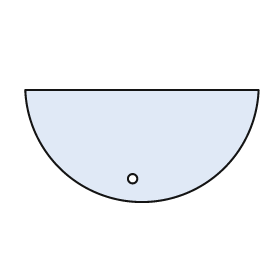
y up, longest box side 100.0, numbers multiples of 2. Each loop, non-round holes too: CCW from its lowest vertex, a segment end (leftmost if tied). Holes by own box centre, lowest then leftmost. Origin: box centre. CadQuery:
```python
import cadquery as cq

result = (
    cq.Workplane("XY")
    .moveTo(-50.0, 24.0)
    .threePointArc((0.0, -24.0), (50.0, 24.0))
    .close()
    .moveTo(-4.0, -14.0)
    .circle(2.0)
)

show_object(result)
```